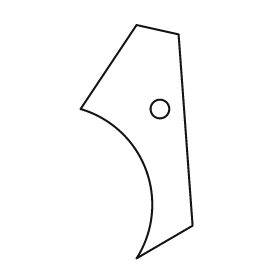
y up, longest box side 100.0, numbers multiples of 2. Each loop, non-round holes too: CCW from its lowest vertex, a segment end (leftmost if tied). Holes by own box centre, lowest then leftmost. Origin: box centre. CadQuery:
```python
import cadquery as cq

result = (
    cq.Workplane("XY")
    .moveTo(0.0, -50.0)
    .lineTo(24.0, -36.0)
    .lineTo(18.0, 46.0)
    .lineTo(0.0, 50.0)
    .lineTo(-24.0, 14.0)
    .threePointArc((4.0, -12.0), (0.0, -50.0))
    .close()
    .moveTo(10.0, 14.0)
    .circle(4.0)
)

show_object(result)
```